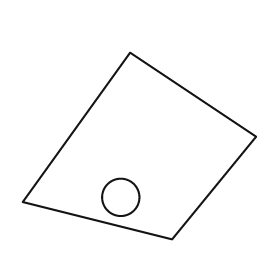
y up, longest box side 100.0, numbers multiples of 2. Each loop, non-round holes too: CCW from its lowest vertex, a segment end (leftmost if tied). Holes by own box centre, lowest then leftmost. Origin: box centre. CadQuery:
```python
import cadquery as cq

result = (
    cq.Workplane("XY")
    .moveTo(14.0, -40.0)
    .lineTo(50.0, 4.0)
    .lineTo(-4.0, 40.0)
    .lineTo(-50.0, -24.0)
    .close()
    .moveTo(-8.0, -22.0)
    .circle(8.0)
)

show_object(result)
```